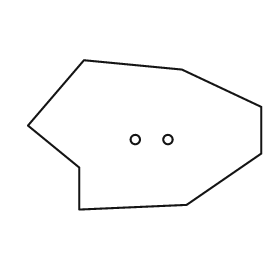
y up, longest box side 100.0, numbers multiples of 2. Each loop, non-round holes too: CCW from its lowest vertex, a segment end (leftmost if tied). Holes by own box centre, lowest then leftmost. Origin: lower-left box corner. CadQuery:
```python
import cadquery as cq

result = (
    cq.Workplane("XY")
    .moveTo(22.0, 0.0)
    .lineTo(68.0, 2.0)
    .lineTo(100.0, 24.0)
    .lineTo(100.0, 44.0)
    .lineTo(66.0, 60.0)
    .lineTo(24.0, 64.0)
    .lineTo(0.0, 36.0)
    .lineTo(22.0, 18.0)
    .close()
    .moveTo(46.0, 30.0)
    .circle(2.0)
    .moveTo(60.0, 30.0)
    .circle(2.0)
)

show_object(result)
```